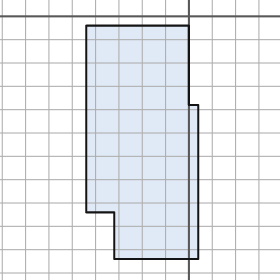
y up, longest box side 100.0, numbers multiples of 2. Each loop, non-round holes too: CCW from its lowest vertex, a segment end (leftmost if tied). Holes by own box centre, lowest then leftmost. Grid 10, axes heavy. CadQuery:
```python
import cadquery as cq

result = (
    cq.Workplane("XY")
    .moveTo(-32.0, -104.0)
    .lineTo(4.0, -104.0)
    .lineTo(4.0, -38.0)
    .lineTo(0.0, -38.0)
    .lineTo(0.0, -4.0)
    .lineTo(-44.0, -4.0)
    .lineTo(-44.0, -84.0)
    .lineTo(-32.0, -84.0)
    .close()
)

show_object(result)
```